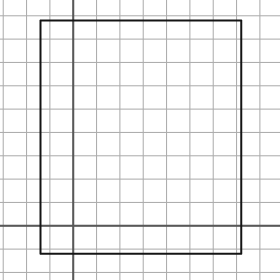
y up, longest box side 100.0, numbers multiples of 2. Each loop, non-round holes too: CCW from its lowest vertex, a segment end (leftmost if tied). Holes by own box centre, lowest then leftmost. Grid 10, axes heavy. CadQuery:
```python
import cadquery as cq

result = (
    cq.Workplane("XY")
    .moveTo(-14.0, -12.0)
    .lineTo(72.0, -12.0)
    .lineTo(72.0, 88.0)
    .lineTo(-14.0, 88.0)
    .close()
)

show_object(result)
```